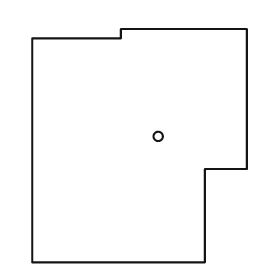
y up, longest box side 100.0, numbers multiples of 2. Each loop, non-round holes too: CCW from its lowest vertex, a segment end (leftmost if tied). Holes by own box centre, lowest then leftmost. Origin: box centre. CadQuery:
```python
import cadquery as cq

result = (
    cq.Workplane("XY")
    .moveTo(-46.0, -50.0)
    .lineTo(28.0, -50.0)
    .lineTo(28.0, -10.0)
    .lineTo(46.0, -10.0)
    .lineTo(46.0, 50.0)
    .lineTo(-8.0, 50.0)
    .lineTo(-8.0, 46.0)
    .lineTo(-46.0, 46.0)
    .close()
    .moveTo(8.0, 4.0)
    .circle(2.0)
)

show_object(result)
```